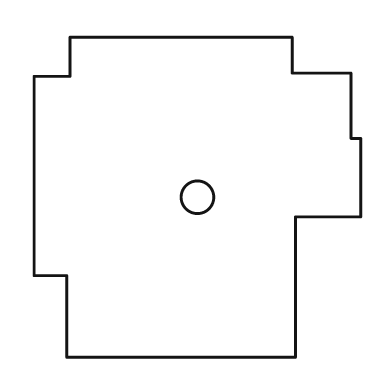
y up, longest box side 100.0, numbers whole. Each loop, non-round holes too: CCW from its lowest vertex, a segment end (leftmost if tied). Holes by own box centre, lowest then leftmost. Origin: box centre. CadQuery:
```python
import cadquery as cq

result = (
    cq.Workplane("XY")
    .moveTo(-40.0, -49.0)
    .lineTo(30.0, -49.0)
    .lineTo(30.0, -6.0)
    .lineTo(50.0, -6.0)
    .lineTo(50.0, 18.0)
    .lineTo(47.0, 18.0)
    .lineTo(47.0, 38.0)
    .lineTo(29.0, 38.0)
    .lineTo(29.0, 49.0)
    .lineTo(-39.0, 49.0)
    .lineTo(-39.0, 37.0)
    .lineTo(-50.0, 37.0)
    .lineTo(-50.0, -24.0)
    .lineTo(-40.0, -24.0)
    .close()
    .moveTo(0.0, 0.0)
    .circle(5.0)
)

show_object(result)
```